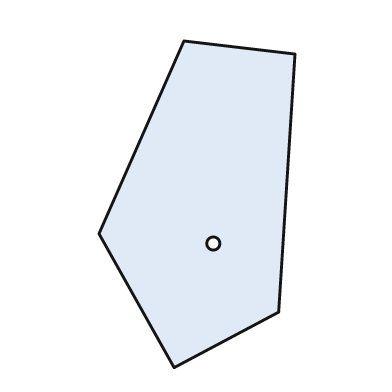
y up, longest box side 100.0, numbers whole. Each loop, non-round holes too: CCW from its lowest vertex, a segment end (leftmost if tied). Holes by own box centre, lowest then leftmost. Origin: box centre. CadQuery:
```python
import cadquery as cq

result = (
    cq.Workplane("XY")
    .moveTo(-7.0, -50.0)
    .lineTo(25.0, -33.0)
    .lineTo(30.0, 46.0)
    .lineTo(-4.0, 50.0)
    .lineTo(-30.0, -9.0)
    .close()
    .moveTo(5.0, -12.0)
    .circle(2.0)
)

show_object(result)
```